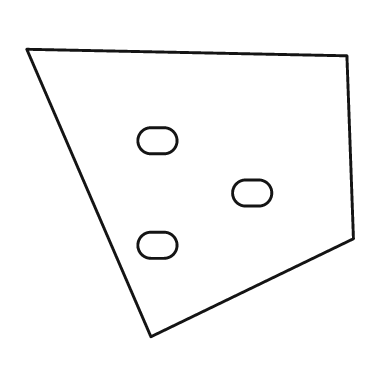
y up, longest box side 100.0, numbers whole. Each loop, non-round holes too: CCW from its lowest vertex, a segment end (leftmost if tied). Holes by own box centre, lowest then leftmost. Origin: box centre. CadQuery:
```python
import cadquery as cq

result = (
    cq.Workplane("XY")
    .moveTo(-12.0, -44.0)
    .lineTo(50.0, -14.0)
    .lineTo(48.0, 42.0)
    .lineTo(-50.0, 44.0)
    .close()
    .moveTo(-12.0, -20.0)
    .lineTo(-8.0, -20.0)
    .threePointArc((-4.0, -16.0), (-8.0, -12.0))
    .lineTo(-12.0, -12.0)
    .threePointArc((-16.0, -16.0), (-12.0, -20.0))
    .close()
    .moveTo(17.0, -4.0)
    .lineTo(21.0, -4.0)
    .threePointArc((25.0, 0.0), (21.0, 4.0))
    .lineTo(17.0, 4.0)
    .threePointArc((13.0, 0.0), (17.0, -4.0))
    .close()
    .moveTo(-12.0, 12.0)
    .lineTo(-8.0, 12.0)
    .threePointArc((-4.0, 16.0), (-8.0, 20.0))
    .lineTo(-12.0, 20.0)
    .threePointArc((-16.0, 16.0), (-12.0, 12.0))
    .close()
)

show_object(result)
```